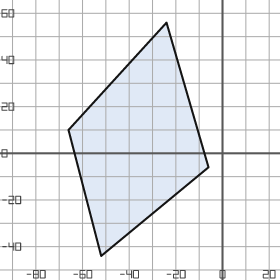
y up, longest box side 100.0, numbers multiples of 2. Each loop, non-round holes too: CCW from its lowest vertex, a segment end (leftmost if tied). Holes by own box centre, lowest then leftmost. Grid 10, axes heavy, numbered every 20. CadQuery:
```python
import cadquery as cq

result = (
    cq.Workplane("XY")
    .moveTo(-52.0, -44.0)
    .lineTo(-6.0, -6.0)
    .lineTo(-24.0, 56.0)
    .lineTo(-66.0, 10.0)
    .close()
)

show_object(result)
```